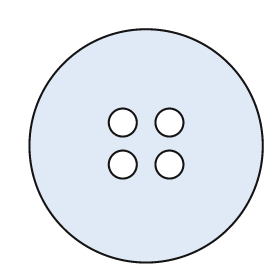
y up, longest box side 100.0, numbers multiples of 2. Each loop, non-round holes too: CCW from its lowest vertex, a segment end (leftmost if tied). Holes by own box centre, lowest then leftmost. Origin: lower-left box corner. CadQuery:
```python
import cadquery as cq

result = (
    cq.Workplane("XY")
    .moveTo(50.0, 50.0)
    .circle(50.0)
    .moveTo(40.0, 42.0)
    .circle(6.0)
    .moveTo(60.0, 42.0)
    .circle(6.0)
    .moveTo(40.0, 60.0)
    .circle(6.0)
    .moveTo(60.0, 60.0)
    .circle(6.0)
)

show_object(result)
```